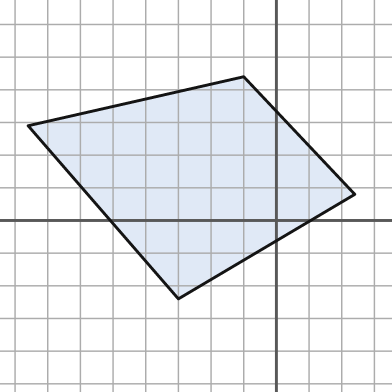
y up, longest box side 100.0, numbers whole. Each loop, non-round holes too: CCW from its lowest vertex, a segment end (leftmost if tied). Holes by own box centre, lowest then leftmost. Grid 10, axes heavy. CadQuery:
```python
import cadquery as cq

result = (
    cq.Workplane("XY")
    .moveTo(-30.0, -24.0)
    .lineTo(24.0, 8.0)
    .lineTo(-10.0, 44.0)
    .lineTo(-76.0, 29.0)
    .close()
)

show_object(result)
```